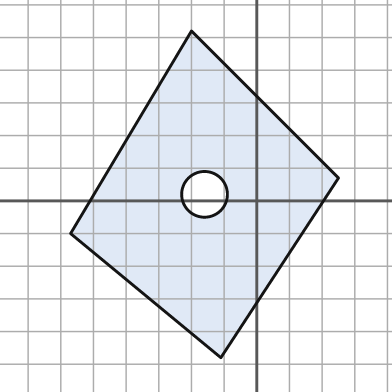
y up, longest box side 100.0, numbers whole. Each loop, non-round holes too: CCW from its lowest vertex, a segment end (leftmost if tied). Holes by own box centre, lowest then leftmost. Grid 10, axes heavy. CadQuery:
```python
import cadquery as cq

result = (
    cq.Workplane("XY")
    .moveTo(-11.0, -48.0)
    .lineTo(25.0, 7.0)
    .lineTo(-20.0, 52.0)
    .lineTo(-57.0, -10.0)
    .close()
    .moveTo(-16.0, 2.0)
    .circle(7.0)
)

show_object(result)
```